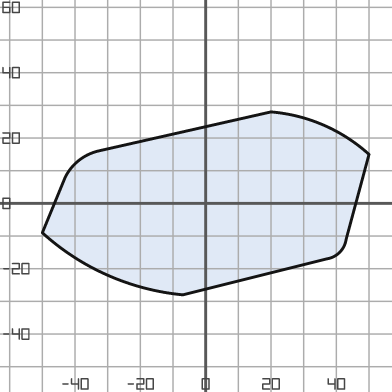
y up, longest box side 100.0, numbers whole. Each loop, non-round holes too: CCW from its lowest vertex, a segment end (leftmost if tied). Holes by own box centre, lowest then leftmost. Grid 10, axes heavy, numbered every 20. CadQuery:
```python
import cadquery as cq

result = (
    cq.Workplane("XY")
    .moveTo(-7.0, -28.0)
    .lineTo(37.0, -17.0)
    .threePointArc((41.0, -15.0), (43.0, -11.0))
    .lineTo(50.0, 15.0)
    .threePointArc((36.0, 24.0), (20.0, 28.0))
    .lineTo(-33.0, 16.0)
    .threePointArc((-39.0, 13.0), (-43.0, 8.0))
    .lineTo(-50.0, -9.0)
    .threePointArc((-30.0, -22.0), (-7.0, -28.0))
    .close()
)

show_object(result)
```